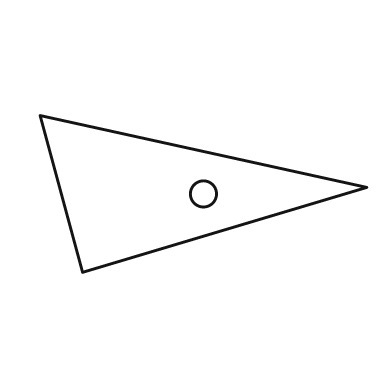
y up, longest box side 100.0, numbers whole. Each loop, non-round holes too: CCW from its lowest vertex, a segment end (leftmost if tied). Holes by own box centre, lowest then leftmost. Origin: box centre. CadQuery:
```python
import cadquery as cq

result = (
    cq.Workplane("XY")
    .moveTo(-37.0, -24.0)
    .lineTo(50.0, 2.0)
    .lineTo(-50.0, 24.0)
    .close()
    .moveTo(0.0, 0.0)
    .circle(4.0)
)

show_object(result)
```